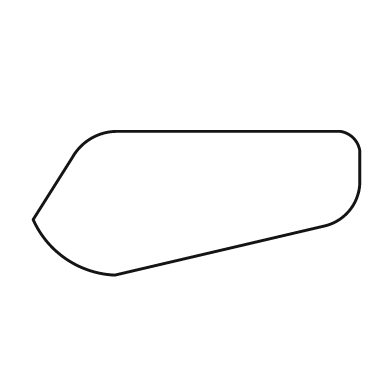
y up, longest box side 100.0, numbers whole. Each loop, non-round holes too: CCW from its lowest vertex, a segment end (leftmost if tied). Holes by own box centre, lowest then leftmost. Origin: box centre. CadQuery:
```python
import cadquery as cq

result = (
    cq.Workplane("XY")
    .moveTo(-25.0, -22.0)
    .lineTo(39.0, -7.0)
    .threePointArc((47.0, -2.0), (50.0, 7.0))
    .lineTo(50.0, 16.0)
    .threePointArc((48.0, 20.0), (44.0, 22.0))
    .lineTo(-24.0, 22.0)
    .threePointArc((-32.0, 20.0), (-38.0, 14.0))
    .lineTo(-50.0, -5.0)
    .threePointArc((-40.0, -17.0), (-25.0, -22.0))
    .close()
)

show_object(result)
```